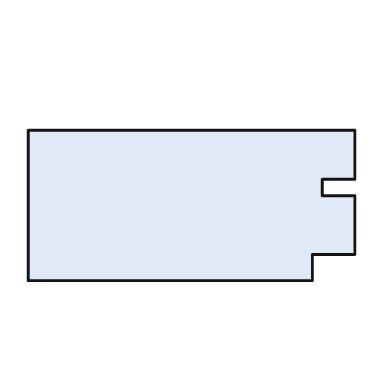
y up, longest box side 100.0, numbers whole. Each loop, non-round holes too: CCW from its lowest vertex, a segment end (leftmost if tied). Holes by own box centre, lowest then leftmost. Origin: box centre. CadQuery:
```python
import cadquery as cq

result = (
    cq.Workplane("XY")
    .moveTo(-50.0, -23.0)
    .lineTo(37.0, -23.0)
    .lineTo(37.0, -15.0)
    .lineTo(50.0, -15.0)
    .lineTo(50.0, 3.0)
    .lineTo(40.0, 3.0)
    .lineTo(40.0, 8.0)
    .lineTo(50.0, 8.0)
    .lineTo(50.0, 23.0)
    .lineTo(-50.0, 23.0)
    .close()
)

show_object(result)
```